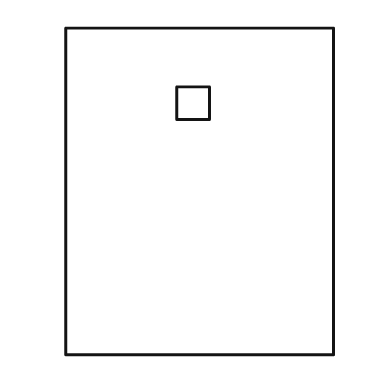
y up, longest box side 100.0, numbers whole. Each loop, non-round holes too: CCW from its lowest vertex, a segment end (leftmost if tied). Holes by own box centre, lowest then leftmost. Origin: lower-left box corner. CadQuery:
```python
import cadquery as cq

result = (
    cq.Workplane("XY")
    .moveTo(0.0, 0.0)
    .lineTo(82.0, 0.0)
    .lineTo(82.0, 100.0)
    .lineTo(0.0, 100.0)
    .close()
    .moveTo(34.0, 72.0)
    .lineTo(44.0, 72.0)
    .lineTo(44.0, 82.0)
    .lineTo(34.0, 82.0)
    .close()
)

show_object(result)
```